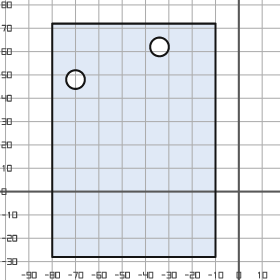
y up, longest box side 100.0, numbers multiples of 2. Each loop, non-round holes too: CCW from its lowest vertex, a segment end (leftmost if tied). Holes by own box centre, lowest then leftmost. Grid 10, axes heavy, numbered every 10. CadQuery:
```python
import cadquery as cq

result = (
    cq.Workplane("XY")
    .moveTo(-80.0, -28.0)
    .lineTo(-10.0, -28.0)
    .lineTo(-10.0, 72.0)
    .lineTo(-80.0, 72.0)
    .close()
    .moveTo(-70.0, 48.0)
    .circle(4.0)
    .moveTo(-34.0, 62.0)
    .circle(4.0)
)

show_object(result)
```